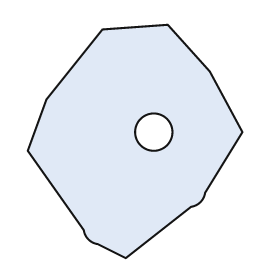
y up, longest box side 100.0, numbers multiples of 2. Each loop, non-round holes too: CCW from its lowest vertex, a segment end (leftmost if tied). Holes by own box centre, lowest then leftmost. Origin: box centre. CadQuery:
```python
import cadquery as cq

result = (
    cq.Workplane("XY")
    .moveTo(-4.0, -50.0)
    .lineTo(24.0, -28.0)
    .threePointArc((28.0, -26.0), (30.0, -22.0))
    .lineTo(46.0, 4.0)
    .lineTo(32.0, 30.0)
    .lineTo(14.0, 50.0)
    .lineTo(-14.0, 48.0)
    .lineTo(-38.0, 18.0)
    .lineTo(-46.0, -4.0)
    .lineTo(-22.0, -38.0)
    .threePointArc((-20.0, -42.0), (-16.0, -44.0))
    .close()
    .moveTo(8.0, 4.0)
    .circle(8.0)
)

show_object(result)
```